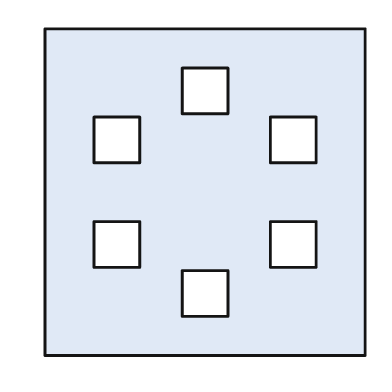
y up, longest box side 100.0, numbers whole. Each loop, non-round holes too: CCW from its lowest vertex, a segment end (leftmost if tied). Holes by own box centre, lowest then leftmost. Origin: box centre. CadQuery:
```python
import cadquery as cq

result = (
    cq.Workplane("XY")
    .moveTo(-49.0, -50.0)
    .lineTo(49.0, -50.0)
    .lineTo(49.0, 50.0)
    .lineTo(-49.0, 50.0)
    .close()
    .moveTo(-7.0, -38.0)
    .lineTo(7.0, -38.0)
    .lineTo(7.0, -24.0)
    .lineTo(-7.0, -24.0)
    .close()
    .moveTo(-34.0, -23.0)
    .lineTo(-20.0, -23.0)
    .lineTo(-20.0, -9.0)
    .lineTo(-34.0, -9.0)
    .close()
    .moveTo(20.0, -23.0)
    .lineTo(34.0, -23.0)
    .lineTo(34.0, -9.0)
    .lineTo(20.0, -9.0)
    .close()
    .moveTo(-34.0, 9.0)
    .lineTo(-20.0, 9.0)
    .lineTo(-20.0, 23.0)
    .lineTo(-34.0, 23.0)
    .close()
    .moveTo(20.0, 9.0)
    .lineTo(34.0, 9.0)
    .lineTo(34.0, 23.0)
    .lineTo(20.0, 23.0)
    .close()
    .moveTo(-7.0, 24.0)
    .lineTo(7.0, 24.0)
    .lineTo(7.0, 38.0)
    .lineTo(-7.0, 38.0)
    .close()
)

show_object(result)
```